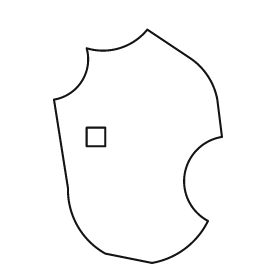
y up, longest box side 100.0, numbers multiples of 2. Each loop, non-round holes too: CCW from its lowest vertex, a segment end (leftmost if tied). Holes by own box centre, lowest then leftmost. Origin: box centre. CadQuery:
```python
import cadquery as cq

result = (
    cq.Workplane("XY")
    .moveTo(6.0, -50.0)
    .threePointArc((20.0, -44.0), (30.0, -32.0))
    .threePointArc((20.0, -12.0), (36.0, 4.0))
    .lineTo(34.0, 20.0)
    .threePointArc((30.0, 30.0), (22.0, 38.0))
    .lineTo(4.0, 50.0)
    .threePointArc((-8.0, 42.0), (-22.0, 42.0))
    .threePointArc((-24.0, 28.0), (-36.0, 20.0))
    .lineTo(-30.0, -18.0)
    .threePointArc((-26.0, -34.0), (-14.0, -46.0))
    .close()
    .moveTo(-22.0, 0.0)
    .lineTo(-14.0, 0.0)
    .lineTo(-14.0, 8.0)
    .lineTo(-22.0, 8.0)
    .close()
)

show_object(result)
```